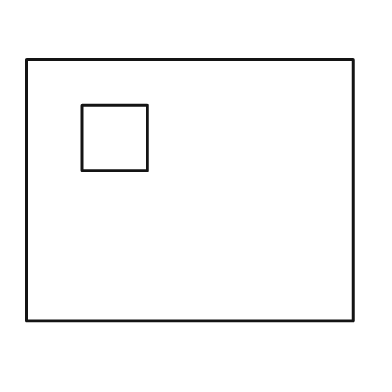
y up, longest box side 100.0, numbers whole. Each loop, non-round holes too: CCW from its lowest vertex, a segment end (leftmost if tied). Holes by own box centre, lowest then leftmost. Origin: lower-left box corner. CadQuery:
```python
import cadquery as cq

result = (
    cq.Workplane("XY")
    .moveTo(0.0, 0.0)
    .lineTo(100.0, 0.0)
    .lineTo(100.0, 80.0)
    .lineTo(0.0, 80.0)
    .close()
    .moveTo(17.0, 46.0)
    .lineTo(37.0, 46.0)
    .lineTo(37.0, 66.0)
    .lineTo(17.0, 66.0)
    .close()
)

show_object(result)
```